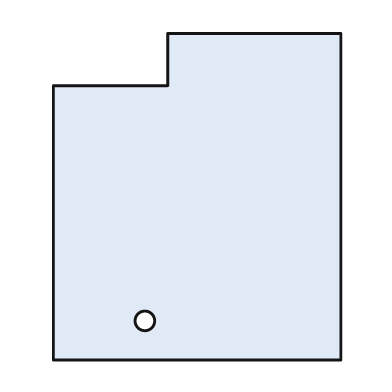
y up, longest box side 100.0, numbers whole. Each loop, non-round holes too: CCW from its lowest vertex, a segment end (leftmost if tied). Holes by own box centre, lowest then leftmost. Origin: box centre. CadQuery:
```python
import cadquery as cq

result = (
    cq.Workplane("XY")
    .moveTo(-44.0, -50.0)
    .lineTo(44.0, -50.0)
    .lineTo(44.0, 50.0)
    .lineTo(-9.0, 50.0)
    .lineTo(-9.0, 34.0)
    .lineTo(-44.0, 34.0)
    .close()
    .moveTo(-16.0, -38.0)
    .circle(3.0)
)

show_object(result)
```